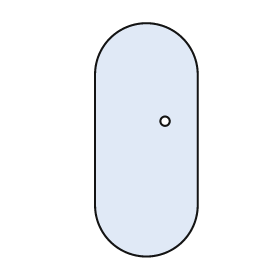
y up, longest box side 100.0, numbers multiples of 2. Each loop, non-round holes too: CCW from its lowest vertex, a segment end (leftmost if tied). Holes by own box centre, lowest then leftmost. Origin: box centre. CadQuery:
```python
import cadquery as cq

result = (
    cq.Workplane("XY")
    .moveTo(-22.0, -28.0)
    .threePointArc((0.0, -50.0), (22.0, -28.0))
    .lineTo(22.0, 28.0)
    .threePointArc((0.0, 50.0), (-22.0, 28.0))
    .close()
    .moveTo(8.0, 8.0)
    .circle(2.0)
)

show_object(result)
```